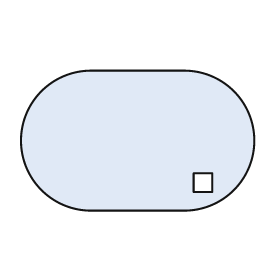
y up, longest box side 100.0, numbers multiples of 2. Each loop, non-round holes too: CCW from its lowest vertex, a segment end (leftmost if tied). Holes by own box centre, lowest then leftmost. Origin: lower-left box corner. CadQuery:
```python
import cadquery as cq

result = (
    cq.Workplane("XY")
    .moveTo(30.0, 0.0)
    .lineTo(70.0, 0.0)
    .threePointArc((100.0, 30.0), (70.0, 60.0))
    .lineTo(30.0, 60.0)
    .threePointArc((0.0, 30.0), (30.0, 0.0))
    .close()
    .moveTo(74.0, 8.0)
    .lineTo(82.0, 8.0)
    .lineTo(82.0, 16.0)
    .lineTo(74.0, 16.0)
    .close()
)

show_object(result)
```